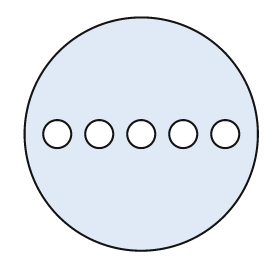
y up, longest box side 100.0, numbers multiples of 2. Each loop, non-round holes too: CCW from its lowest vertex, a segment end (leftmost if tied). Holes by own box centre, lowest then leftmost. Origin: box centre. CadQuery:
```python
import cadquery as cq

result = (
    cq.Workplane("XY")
    .moveTo(0.0, 0.0)
    .circle(50.0)
    .moveTo(-36.0, 0.0)
    .circle(6.0)
    .moveTo(-18.0, 0.0)
    .circle(6.0)
    .moveTo(0.0, 0.0)
    .circle(6.0)
    .moveTo(18.0, 0.0)
    .circle(6.0)
    .moveTo(36.0, 0.0)
    .circle(6.0)
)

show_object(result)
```